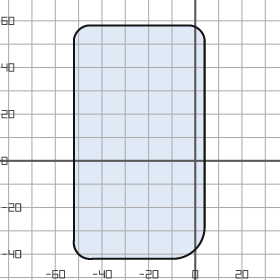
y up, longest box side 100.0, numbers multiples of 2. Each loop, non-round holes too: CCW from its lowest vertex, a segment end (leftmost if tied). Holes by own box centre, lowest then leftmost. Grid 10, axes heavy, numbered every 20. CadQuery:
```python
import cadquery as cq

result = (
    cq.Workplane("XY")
    .moveTo(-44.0, -42.0)
    .lineTo(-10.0, -42.0)
    .threePointArc((0.0, -38.0), (4.0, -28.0))
    .lineTo(4.0, 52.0)
    .threePointArc((2.0, 56.0), (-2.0, 58.0))
    .lineTo(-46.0, 58.0)
    .threePointArc((-50.0, 56.0), (-52.0, 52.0))
    .lineTo(-52.0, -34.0)
    .threePointArc((-50.0, -40.0), (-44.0, -42.0))
    .close()
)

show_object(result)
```